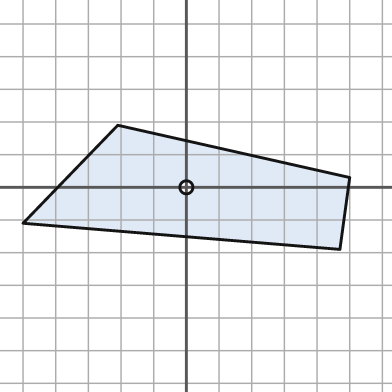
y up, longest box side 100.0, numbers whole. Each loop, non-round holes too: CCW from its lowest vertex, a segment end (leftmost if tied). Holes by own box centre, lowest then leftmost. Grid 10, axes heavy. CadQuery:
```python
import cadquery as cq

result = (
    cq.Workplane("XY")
    .moveTo(47.0, -19.0)
    .lineTo(50.0, 3.0)
    .lineTo(-21.0, 19.0)
    .lineTo(-50.0, -11.0)
    .close()
    .moveTo(0.0, 0.0)
    .circle(2.0)
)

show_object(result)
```